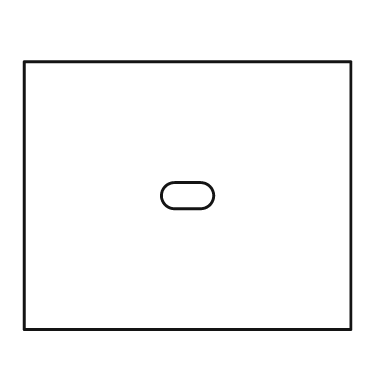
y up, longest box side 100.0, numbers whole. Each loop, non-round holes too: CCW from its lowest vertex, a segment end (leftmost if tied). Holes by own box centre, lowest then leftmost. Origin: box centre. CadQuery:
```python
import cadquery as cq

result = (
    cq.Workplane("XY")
    .moveTo(-50.0, -41.0)
    .lineTo(50.0, -41.0)
    .lineTo(50.0, 41.0)
    .lineTo(-50.0, 41.0)
    .close()
    .moveTo(-4.0, -4.0)
    .lineTo(4.0, -4.0)
    .threePointArc((8.0, 0.0), (4.0, 4.0))
    .lineTo(-4.0, 4.0)
    .threePointArc((-8.0, 0.0), (-4.0, -4.0))
    .close()
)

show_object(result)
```